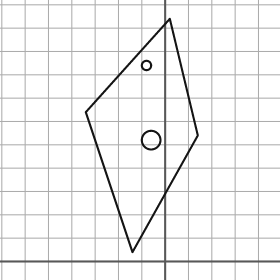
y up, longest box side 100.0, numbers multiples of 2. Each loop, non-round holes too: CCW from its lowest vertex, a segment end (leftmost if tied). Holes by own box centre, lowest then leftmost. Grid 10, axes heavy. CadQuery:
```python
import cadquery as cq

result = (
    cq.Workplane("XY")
    .moveTo(-14.0, 4.0)
    .lineTo(14.0, 54.0)
    .lineTo(2.0, 104.0)
    .lineTo(-34.0, 64.0)
    .close()
    .moveTo(-6.0, 52.0)
    .circle(4.0)
    .moveTo(-8.0, 84.0)
    .circle(2.0)
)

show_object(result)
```